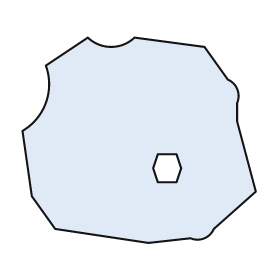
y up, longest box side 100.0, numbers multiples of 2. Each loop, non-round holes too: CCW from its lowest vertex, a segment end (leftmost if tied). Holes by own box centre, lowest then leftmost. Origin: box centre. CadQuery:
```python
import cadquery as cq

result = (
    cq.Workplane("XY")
    .moveTo(4.0, -44.0)
    .lineTo(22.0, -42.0)
    .threePointArc((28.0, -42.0), (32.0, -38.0))
    .lineTo(50.0, -22.0)
    .lineTo(42.0, 8.0)
    .lineTo(42.0, 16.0)
    .threePointArc((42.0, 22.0), (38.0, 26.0))
    .lineTo(28.0, 40.0)
    .lineTo(-2.0, 44.0)
    .threePointArc((-12.0, 40.0), (-22.0, 44.0))
    .lineTo(-40.0, 32.0)
    .threePointArc((-40.0, 16.0), (-50.0, 4.0))
    .lineTo(-46.0, -24.0)
    .lineTo(-36.0, -38.0)
    .close()
    .moveTo(8.0, -18.0)
    .lineTo(16.0, -18.0)
    .lineTo(18.0, -12.0)
    .lineTo(16.0, -6.0)
    .lineTo(8.0, -6.0)
    .lineTo(6.0, -12.0)
    .close()
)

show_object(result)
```